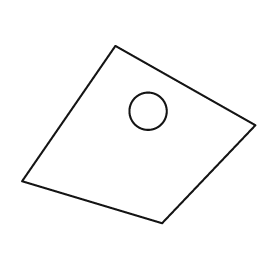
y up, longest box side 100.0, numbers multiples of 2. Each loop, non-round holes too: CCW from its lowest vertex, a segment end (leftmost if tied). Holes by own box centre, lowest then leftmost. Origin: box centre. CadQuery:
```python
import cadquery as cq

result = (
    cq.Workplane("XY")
    .moveTo(10.0, -38.0)
    .lineTo(50.0, 4.0)
    .lineTo(-10.0, 38.0)
    .lineTo(-50.0, -20.0)
    .close()
    .moveTo(4.0, 10.0)
    .circle(8.0)
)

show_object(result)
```